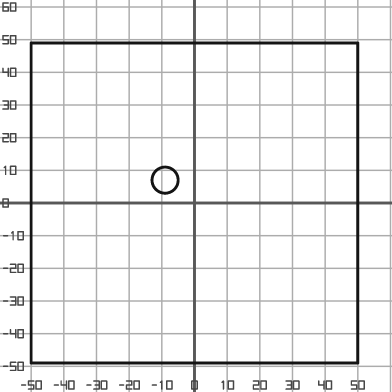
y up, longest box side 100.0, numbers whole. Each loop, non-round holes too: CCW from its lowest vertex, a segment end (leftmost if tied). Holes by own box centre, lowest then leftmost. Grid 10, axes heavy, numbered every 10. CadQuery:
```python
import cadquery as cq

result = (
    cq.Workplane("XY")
    .moveTo(-50.0, -49.0)
    .lineTo(50.0, -49.0)
    .lineTo(50.0, 49.0)
    .lineTo(-50.0, 49.0)
    .close()
    .moveTo(-9.0, 7.0)
    .circle(4.0)
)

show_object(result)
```